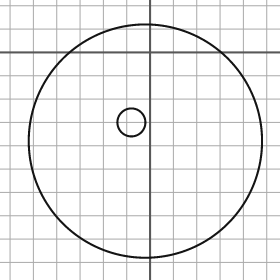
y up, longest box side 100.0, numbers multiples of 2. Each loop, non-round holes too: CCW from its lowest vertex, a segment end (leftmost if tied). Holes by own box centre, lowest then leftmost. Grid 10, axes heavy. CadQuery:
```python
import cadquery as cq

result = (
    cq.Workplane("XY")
    .moveTo(-2.0, -38.0)
    .circle(50.0)
    .moveTo(-8.0, -30.0)
    .circle(6.0)
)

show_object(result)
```